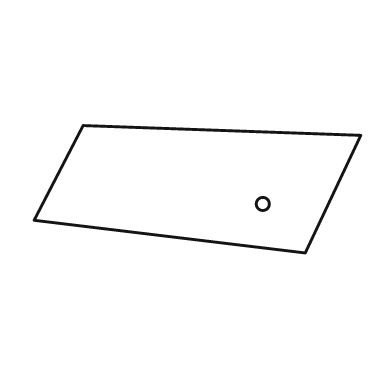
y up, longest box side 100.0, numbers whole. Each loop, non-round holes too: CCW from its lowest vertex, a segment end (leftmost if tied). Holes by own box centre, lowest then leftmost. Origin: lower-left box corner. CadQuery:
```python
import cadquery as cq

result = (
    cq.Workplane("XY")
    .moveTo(83.0, 0.0)
    .lineTo(100.0, 36.0)
    .lineTo(15.0, 39.0)
    .lineTo(0.0, 10.0)
    .close()
    .moveTo(70.0, 15.0)
    .circle(2.0)
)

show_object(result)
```